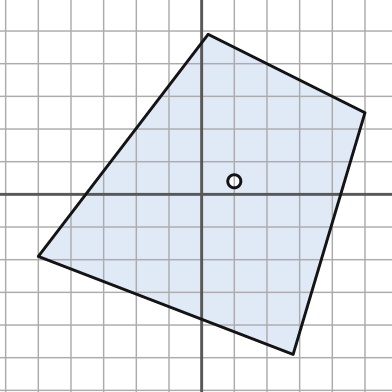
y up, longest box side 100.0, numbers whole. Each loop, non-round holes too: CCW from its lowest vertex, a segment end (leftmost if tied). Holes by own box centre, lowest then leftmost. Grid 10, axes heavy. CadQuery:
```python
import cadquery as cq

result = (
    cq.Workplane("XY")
    .moveTo(28.0, -49.0)
    .lineTo(50.0, 25.0)
    .lineTo(2.0, 49.0)
    .lineTo(-50.0, -19.0)
    .close()
    .moveTo(10.0, 4.0)
    .circle(2.0)
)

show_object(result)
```